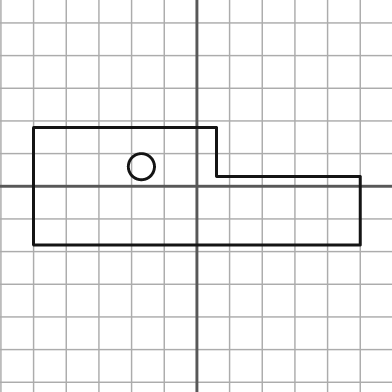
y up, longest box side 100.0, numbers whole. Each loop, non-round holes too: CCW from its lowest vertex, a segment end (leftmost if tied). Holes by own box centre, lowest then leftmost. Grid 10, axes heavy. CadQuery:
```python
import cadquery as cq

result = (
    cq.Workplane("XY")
    .moveTo(-50.0, -18.0)
    .lineTo(50.0, -18.0)
    .lineTo(50.0, 3.0)
    .lineTo(6.0, 3.0)
    .lineTo(6.0, 18.0)
    .lineTo(-50.0, 18.0)
    .close()
    .moveTo(-17.0, 6.0)
    .circle(4.0)
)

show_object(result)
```